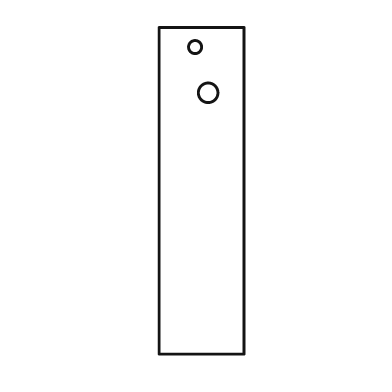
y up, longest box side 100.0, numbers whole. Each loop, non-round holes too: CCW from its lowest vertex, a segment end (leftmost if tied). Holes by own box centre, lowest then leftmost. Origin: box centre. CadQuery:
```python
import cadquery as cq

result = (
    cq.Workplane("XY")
    .moveTo(-13.0, -50.0)
    .lineTo(13.0, -50.0)
    .lineTo(13.0, 50.0)
    .lineTo(-13.0, 50.0)
    .close()
    .moveTo(2.0, 30.0)
    .circle(3.0)
    .moveTo(-2.0, 44.0)
    .circle(2.0)
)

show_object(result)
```